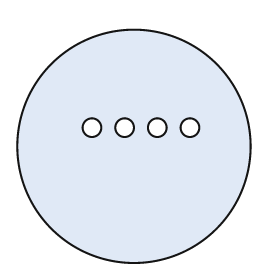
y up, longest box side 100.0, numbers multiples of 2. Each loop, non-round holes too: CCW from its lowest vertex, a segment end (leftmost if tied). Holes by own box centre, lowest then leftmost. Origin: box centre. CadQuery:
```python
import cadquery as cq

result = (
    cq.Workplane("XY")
    .moveTo(0.0, 0.0)
    .circle(50.0)
    .moveTo(-18.0, 8.0)
    .circle(4.0)
    .moveTo(-4.0, 8.0)
    .circle(4.0)
    .moveTo(10.0, 8.0)
    .circle(4.0)
    .moveTo(24.0, 8.0)
    .circle(4.0)
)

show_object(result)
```